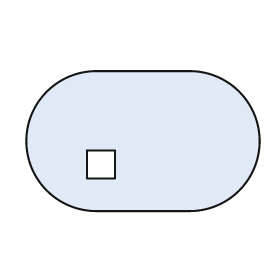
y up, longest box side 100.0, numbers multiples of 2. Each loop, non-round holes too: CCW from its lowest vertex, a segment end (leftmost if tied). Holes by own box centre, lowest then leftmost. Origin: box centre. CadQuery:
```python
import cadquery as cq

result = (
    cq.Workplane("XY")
    .moveTo(-20.0, -30.0)
    .lineTo(20.0, -30.0)
    .threePointArc((50.0, 0.0), (20.0, 30.0))
    .lineTo(-20.0, 30.0)
    .threePointArc((-50.0, 0.0), (-20.0, -30.0))
    .close()
    .moveTo(-24.0, -16.0)
    .lineTo(-12.0, -16.0)
    .lineTo(-12.0, -4.0)
    .lineTo(-24.0, -4.0)
    .close()
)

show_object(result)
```